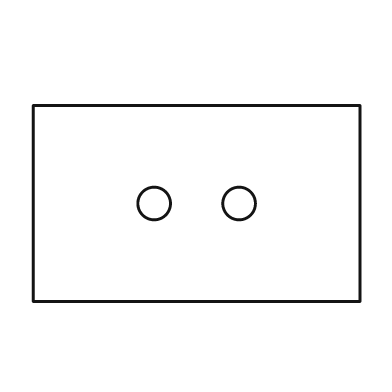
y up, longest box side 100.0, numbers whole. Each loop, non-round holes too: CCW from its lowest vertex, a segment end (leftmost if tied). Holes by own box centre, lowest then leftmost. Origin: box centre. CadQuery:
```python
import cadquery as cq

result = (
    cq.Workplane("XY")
    .moveTo(-50.0, -30.0)
    .lineTo(50.0, -30.0)
    .lineTo(50.0, 30.0)
    .lineTo(-50.0, 30.0)
    .close()
    .moveTo(-13.0, 0.0)
    .circle(5.0)
    .moveTo(13.0, 0.0)
    .circle(5.0)
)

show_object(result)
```